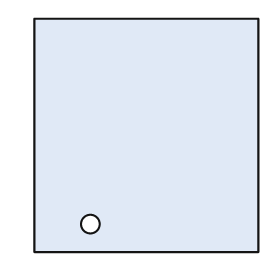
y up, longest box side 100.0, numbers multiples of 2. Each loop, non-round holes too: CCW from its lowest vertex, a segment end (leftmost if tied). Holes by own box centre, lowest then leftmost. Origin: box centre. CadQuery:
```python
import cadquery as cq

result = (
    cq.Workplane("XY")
    .moveTo(-48.0, -50.0)
    .lineTo(48.0, -50.0)
    .lineTo(48.0, 50.0)
    .lineTo(-48.0, 50.0)
    .close()
    .moveTo(-24.0, -38.0)
    .circle(4.0)
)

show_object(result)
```